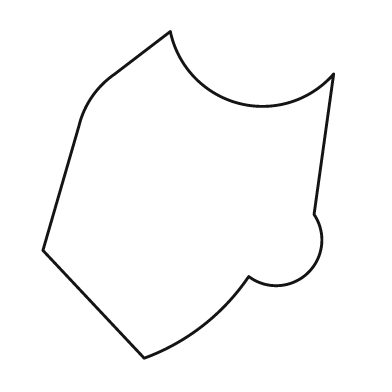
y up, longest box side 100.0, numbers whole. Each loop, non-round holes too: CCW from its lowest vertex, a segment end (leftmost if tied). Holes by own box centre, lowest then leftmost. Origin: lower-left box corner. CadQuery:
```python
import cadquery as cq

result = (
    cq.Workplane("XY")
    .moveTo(31.0, 0.0)
    .threePointArc((49.0, 10.0), (63.0, 25.0))
    .threePointArc((81.0, 26.0), (83.0, 44.0))
    .lineTo(89.0, 87.0)
    .threePointArc((60.0, 78.0), (39.0, 100.0))
    .lineTo(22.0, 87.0)
    .threePointArc((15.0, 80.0), (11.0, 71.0))
    .lineTo(0.0, 33.0)
    .close()
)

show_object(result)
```